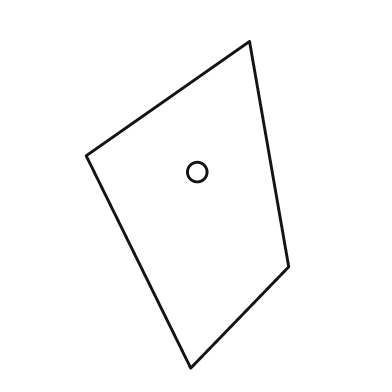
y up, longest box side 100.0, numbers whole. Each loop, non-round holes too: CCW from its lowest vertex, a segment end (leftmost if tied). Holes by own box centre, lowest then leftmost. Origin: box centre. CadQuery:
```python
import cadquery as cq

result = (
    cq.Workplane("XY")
    .moveTo(1.0, -50.0)
    .lineTo(31.0, -19.0)
    .lineTo(19.0, 50.0)
    .lineTo(-31.0, 15.0)
    .close()
    .moveTo(3.0, 10.0)
    .circle(3.0)
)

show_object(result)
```